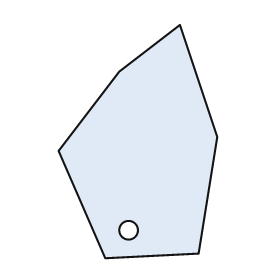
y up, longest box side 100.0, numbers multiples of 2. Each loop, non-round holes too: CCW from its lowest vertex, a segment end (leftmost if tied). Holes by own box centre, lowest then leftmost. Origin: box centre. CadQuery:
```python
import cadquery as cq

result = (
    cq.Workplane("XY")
    .moveTo(-14.0, -50.0)
    .lineTo(26.0, -48.0)
    .lineTo(34.0, 2.0)
    .lineTo(18.0, 50.0)
    .lineTo(-8.0, 30.0)
    .lineTo(-34.0, -4.0)
    .close()
    .moveTo(-4.0, -38.0)
    .circle(4.0)
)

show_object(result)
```